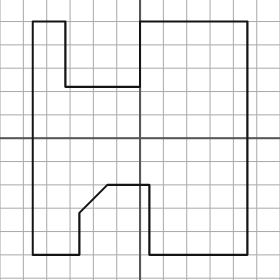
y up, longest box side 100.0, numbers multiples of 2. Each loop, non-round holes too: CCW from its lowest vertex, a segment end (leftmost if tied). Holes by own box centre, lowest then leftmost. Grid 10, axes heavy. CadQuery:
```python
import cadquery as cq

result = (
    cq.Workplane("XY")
    .moveTo(-46.0, -50.0)
    .lineTo(-26.0, -50.0)
    .lineTo(-26.0, -32.0)
    .lineTo(-14.0, -20.0)
    .lineTo(4.0, -20.0)
    .lineTo(4.0, -50.0)
    .lineTo(46.0, -50.0)
    .lineTo(46.0, 50.0)
    .lineTo(0.0, 50.0)
    .lineTo(0.0, 22.0)
    .lineTo(-32.0, 22.0)
    .lineTo(-32.0, 50.0)
    .lineTo(-46.0, 50.0)
    .close()
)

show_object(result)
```